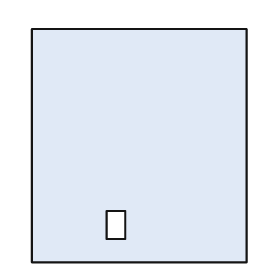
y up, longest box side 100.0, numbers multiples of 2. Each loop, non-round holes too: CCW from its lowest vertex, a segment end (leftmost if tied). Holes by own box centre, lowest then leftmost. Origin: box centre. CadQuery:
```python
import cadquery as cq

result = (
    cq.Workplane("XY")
    .moveTo(-46.0, -50.0)
    .lineTo(46.0, -50.0)
    .lineTo(46.0, 50.0)
    .lineTo(-46.0, 50.0)
    .close()
    .moveTo(-14.0, -40.0)
    .lineTo(-6.0, -40.0)
    .lineTo(-6.0, -28.0)
    .lineTo(-14.0, -28.0)
    .close()
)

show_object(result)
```